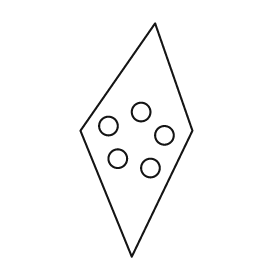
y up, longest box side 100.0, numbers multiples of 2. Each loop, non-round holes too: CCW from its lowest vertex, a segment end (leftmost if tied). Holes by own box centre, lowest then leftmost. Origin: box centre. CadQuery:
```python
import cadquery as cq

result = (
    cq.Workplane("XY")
    .moveTo(-2.0, -50.0)
    .lineTo(24.0, 4.0)
    .lineTo(8.0, 50.0)
    .lineTo(-24.0, 4.0)
    .close()
    .moveTo(6.0, -12.0)
    .circle(4.0)
    .moveTo(-8.0, -8.0)
    .circle(4.0)
    .moveTo(12.0, 2.0)
    .circle(4.0)
    .moveTo(-12.0, 6.0)
    .circle(4.0)
    .moveTo(2.0, 12.0)
    .circle(4.0)
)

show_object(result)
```